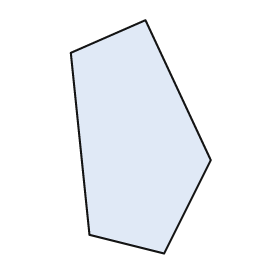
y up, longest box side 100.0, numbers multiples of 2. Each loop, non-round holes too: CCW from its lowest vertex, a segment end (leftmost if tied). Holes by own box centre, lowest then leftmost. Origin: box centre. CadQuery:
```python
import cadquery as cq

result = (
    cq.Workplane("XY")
    .moveTo(10.0, -50.0)
    .lineTo(30.0, -10.0)
    .lineTo(2.0, 50.0)
    .lineTo(-30.0, 36.0)
    .lineTo(-22.0, -42.0)
    .close()
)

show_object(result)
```